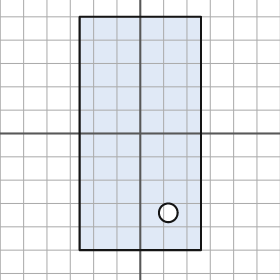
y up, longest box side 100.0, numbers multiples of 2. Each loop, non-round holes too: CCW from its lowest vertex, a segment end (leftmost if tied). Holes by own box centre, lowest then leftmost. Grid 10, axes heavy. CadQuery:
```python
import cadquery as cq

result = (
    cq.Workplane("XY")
    .moveTo(-26.0, -50.0)
    .lineTo(26.0, -50.0)
    .lineTo(26.0, 50.0)
    .lineTo(-26.0, 50.0)
    .close()
    .moveTo(12.0, -34.0)
    .circle(4.0)
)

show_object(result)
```